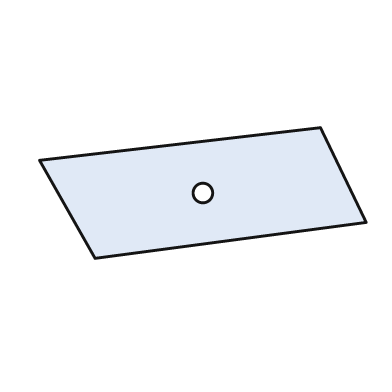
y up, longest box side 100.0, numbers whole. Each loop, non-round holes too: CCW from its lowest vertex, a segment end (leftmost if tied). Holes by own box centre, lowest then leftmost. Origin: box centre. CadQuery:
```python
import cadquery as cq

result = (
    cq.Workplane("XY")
    .moveTo(-33.0, -20.0)
    .lineTo(50.0, -9.0)
    .lineTo(36.0, 20.0)
    .lineTo(-50.0, 10.0)
    .close()
    .moveTo(0.0, 0.0)
    .circle(3.0)
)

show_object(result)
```